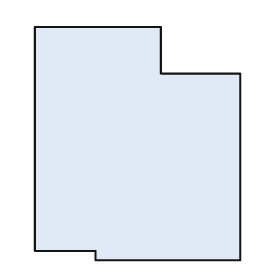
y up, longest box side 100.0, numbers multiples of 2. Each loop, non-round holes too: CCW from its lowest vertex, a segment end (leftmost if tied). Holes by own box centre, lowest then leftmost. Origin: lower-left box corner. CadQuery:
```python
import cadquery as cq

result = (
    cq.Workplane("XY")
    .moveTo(26.0, 0.0)
    .lineTo(88.0, 0.0)
    .lineTo(88.0, 80.0)
    .lineTo(54.0, 80.0)
    .lineTo(54.0, 100.0)
    .lineTo(0.0, 100.0)
    .lineTo(0.0, 4.0)
    .lineTo(26.0, 4.0)
    .close()
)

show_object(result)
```